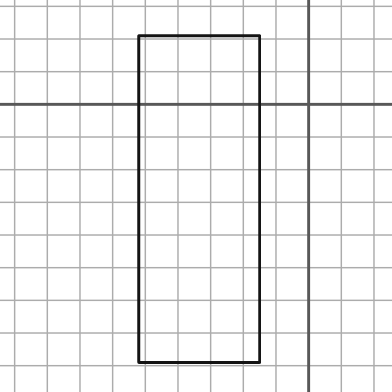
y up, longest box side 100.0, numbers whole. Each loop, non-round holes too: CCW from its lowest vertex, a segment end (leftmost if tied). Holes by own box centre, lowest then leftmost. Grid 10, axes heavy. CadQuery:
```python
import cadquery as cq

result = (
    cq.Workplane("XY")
    .moveTo(-52.0, -79.0)
    .lineTo(-15.0, -79.0)
    .lineTo(-15.0, 21.0)
    .lineTo(-52.0, 21.0)
    .close()
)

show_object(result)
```